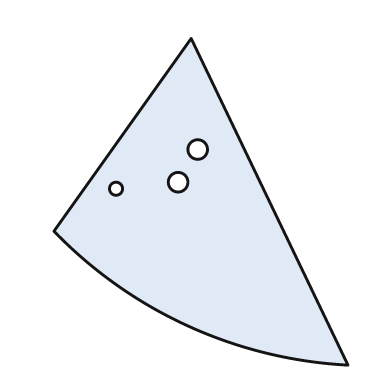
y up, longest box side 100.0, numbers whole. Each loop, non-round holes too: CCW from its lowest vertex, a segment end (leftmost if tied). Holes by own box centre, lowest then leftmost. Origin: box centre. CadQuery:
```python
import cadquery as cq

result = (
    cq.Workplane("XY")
    .moveTo(45.0, -50.0)
    .lineTo(-3.0, 50.0)
    .lineTo(-45.0, -9.0)
    .threePointArc((-4.0, -38.0), (45.0, -50.0))
    .close()
    .moveTo(-26.0, 4.0)
    .circle(2.0)
    .moveTo(-7.0, 6.0)
    .circle(3.0)
    .moveTo(-1.0, 16.0)
    .circle(3.0)
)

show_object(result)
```